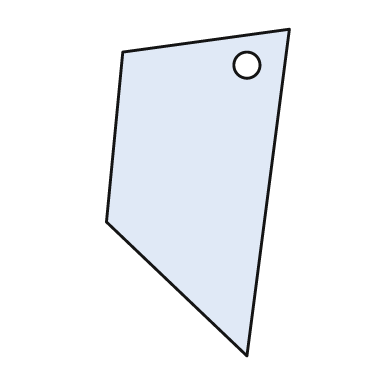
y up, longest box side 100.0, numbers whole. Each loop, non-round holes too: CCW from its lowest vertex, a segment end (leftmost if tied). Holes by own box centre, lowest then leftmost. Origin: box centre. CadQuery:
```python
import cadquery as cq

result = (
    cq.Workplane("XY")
    .moveTo(15.0, -50.0)
    .lineTo(28.0, 50.0)
    .lineTo(-23.0, 43.0)
    .lineTo(-28.0, -9.0)
    .close()
    .moveTo(15.0, 39.0)
    .circle(4.0)
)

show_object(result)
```